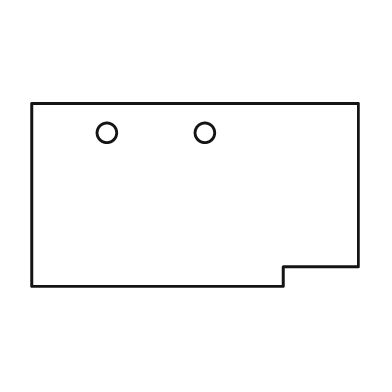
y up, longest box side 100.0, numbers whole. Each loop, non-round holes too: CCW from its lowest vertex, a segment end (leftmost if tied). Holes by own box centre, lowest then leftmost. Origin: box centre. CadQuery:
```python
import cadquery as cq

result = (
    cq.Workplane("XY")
    .moveTo(-50.0, -28.0)
    .lineTo(27.0, -28.0)
    .lineTo(27.0, -22.0)
    .lineTo(50.0, -22.0)
    .lineTo(50.0, 28.0)
    .lineTo(-50.0, 28.0)
    .close()
    .moveTo(-27.0, 19.0)
    .circle(3.0)
    .moveTo(3.0, 19.0)
    .circle(3.0)
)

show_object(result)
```